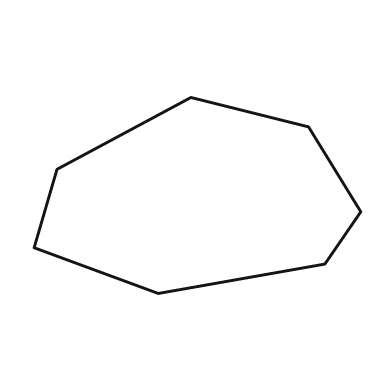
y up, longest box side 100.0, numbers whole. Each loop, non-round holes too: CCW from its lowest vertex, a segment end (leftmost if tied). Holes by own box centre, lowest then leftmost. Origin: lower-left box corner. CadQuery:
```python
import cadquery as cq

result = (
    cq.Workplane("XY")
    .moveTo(38.0, 0.0)
    .lineTo(89.0, 9.0)
    .lineTo(100.0, 25.0)
    .lineTo(84.0, 51.0)
    .lineTo(48.0, 60.0)
    .lineTo(7.0, 38.0)
    .lineTo(0.0, 14.0)
    .close()
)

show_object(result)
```